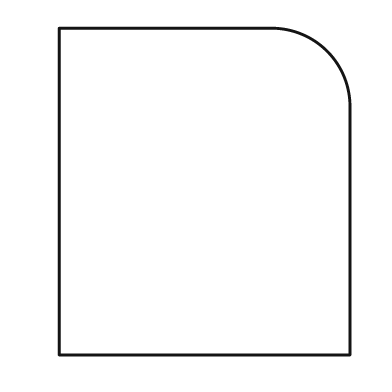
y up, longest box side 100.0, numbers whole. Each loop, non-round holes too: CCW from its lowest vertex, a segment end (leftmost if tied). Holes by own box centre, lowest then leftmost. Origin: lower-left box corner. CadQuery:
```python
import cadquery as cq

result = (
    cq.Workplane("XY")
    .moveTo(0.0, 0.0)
    .lineTo(89.0, 0.0)
    .lineTo(89.0, 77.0)
    .threePointArc((82.0, 93.0), (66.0, 100.0))
    .lineTo(0.0, 100.0)
    .close()
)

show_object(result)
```